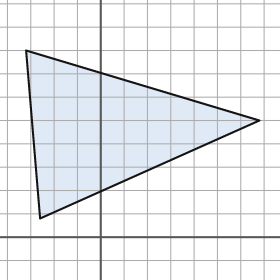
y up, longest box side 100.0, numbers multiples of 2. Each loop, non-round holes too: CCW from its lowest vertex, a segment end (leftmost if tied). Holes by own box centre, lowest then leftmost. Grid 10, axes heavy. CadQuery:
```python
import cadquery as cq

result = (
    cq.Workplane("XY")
    .moveTo(-26.0, 8.0)
    .lineTo(68.0, 50.0)
    .lineTo(-32.0, 80.0)
    .close()
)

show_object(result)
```